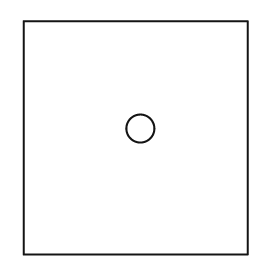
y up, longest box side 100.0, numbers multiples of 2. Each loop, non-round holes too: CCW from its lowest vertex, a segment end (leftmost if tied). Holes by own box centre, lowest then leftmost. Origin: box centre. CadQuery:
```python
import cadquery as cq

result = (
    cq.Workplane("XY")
    .moveTo(-48.0, -50.0)
    .lineTo(48.0, -50.0)
    .lineTo(48.0, 50.0)
    .lineTo(-48.0, 50.0)
    .close()
    .moveTo(2.0, 4.0)
    .circle(6.0)
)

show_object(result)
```